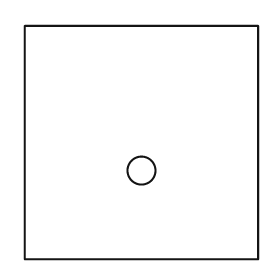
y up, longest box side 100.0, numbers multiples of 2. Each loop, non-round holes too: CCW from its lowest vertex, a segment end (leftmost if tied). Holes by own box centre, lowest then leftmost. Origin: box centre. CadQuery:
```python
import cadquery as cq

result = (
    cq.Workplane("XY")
    .moveTo(-50.0, -50.0)
    .lineTo(50.0, -50.0)
    .lineTo(50.0, 50.0)
    .lineTo(-50.0, 50.0)
    .close()
    .moveTo(0.0, -12.0)
    .circle(6.0)
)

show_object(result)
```